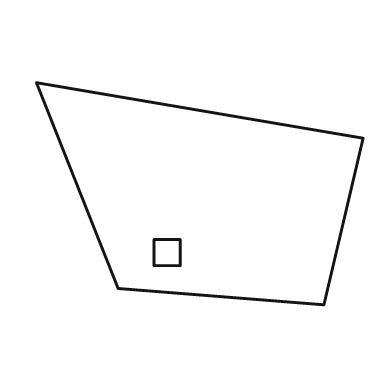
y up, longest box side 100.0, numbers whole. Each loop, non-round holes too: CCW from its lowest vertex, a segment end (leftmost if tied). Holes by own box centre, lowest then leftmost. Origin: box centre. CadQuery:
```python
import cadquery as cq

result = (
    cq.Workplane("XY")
    .moveTo(38.0, -34.0)
    .lineTo(50.0, 17.0)
    .lineTo(-50.0, 34.0)
    .lineTo(-25.0, -29.0)
    .close()
    .moveTo(-14.0, -22.0)
    .lineTo(-6.0, -22.0)
    .lineTo(-6.0, -14.0)
    .lineTo(-14.0, -14.0)
    .close()
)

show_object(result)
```